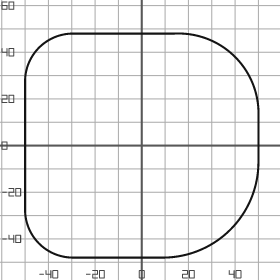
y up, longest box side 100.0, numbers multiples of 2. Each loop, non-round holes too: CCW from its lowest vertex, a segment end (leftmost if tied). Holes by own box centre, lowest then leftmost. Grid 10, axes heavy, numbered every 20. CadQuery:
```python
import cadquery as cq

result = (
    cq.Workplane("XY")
    .moveTo(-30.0, -48.0)
    .lineTo(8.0, -48.0)
    .threePointArc((38.0, -36.0), (50.0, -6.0))
    .lineTo(50.0, 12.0)
    .threePointArc((40.0, 38.0), (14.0, 48.0))
    .lineTo(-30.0, 48.0)
    .threePointArc((-44.0, 42.0), (-50.0, 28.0))
    .lineTo(-50.0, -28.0)
    .threePointArc((-44.0, -42.0), (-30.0, -48.0))
    .close()
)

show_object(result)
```